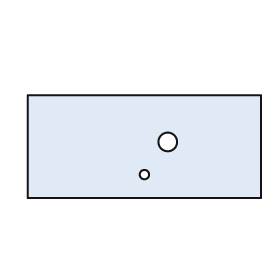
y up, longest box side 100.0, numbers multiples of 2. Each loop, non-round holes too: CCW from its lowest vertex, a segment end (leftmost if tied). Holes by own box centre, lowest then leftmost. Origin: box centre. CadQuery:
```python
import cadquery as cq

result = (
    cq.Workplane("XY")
    .moveTo(-50.0, -22.0)
    .lineTo(50.0, -22.0)
    .lineTo(50.0, 22.0)
    .lineTo(-50.0, 22.0)
    .close()
    .moveTo(0.0, -12.0)
    .circle(2.0)
    .moveTo(10.0, 2.0)
    .circle(4.0)
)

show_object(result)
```